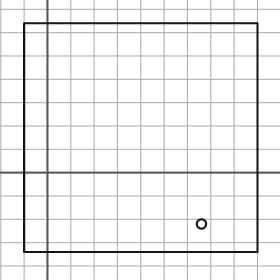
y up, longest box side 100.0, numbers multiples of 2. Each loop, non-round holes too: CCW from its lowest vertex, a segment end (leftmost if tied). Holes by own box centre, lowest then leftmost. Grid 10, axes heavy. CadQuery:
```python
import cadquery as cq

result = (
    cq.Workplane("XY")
    .moveTo(-10.0, -34.0)
    .lineTo(90.0, -34.0)
    .lineTo(90.0, 64.0)
    .lineTo(-10.0, 64.0)
    .close()
    .moveTo(66.0, -22.0)
    .circle(2.0)
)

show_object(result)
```